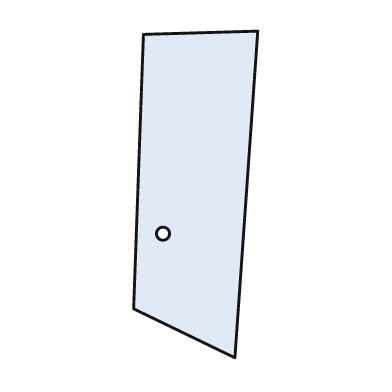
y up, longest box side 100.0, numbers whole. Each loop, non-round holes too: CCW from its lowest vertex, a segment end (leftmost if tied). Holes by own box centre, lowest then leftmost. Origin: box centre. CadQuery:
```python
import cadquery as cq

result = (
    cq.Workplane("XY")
    .moveTo(12.0, -50.0)
    .lineTo(19.0, 50.0)
    .lineTo(-16.0, 49.0)
    .lineTo(-19.0, -35.0)
    .close()
    .moveTo(-10.0, -12.0)
    .circle(2.0)
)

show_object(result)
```